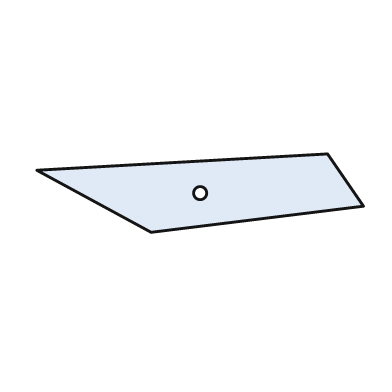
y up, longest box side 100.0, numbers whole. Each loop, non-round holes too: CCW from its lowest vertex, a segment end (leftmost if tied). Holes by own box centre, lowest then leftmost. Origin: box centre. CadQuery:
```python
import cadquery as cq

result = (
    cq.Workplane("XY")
    .moveTo(-15.0, -12.0)
    .lineTo(50.0, -4.0)
    .lineTo(39.0, 12.0)
    .lineTo(-50.0, 7.0)
    .close()
    .moveTo(0.0, 0.0)
    .circle(2.0)
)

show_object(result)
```